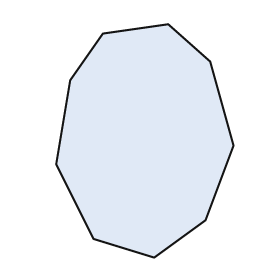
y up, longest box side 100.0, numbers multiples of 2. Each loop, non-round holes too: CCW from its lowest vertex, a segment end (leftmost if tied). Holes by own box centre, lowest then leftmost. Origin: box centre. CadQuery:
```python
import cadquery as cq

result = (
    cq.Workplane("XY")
    .moveTo(4.0, -50.0)
    .lineTo(26.0, -34.0)
    .lineTo(38.0, -2.0)
    .lineTo(28.0, 34.0)
    .lineTo(10.0, 50.0)
    .lineTo(-18.0, 46.0)
    .lineTo(-32.0, 26.0)
    .lineTo(-38.0, -10.0)
    .lineTo(-22.0, -42.0)
    .close()
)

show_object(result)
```